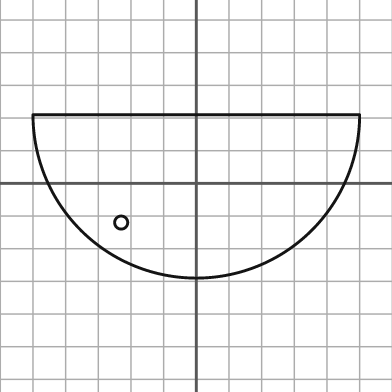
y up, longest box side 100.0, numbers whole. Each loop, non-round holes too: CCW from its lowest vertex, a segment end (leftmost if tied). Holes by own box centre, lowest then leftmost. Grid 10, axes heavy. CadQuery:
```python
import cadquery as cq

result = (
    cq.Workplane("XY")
    .moveTo(-50.0, 21.0)
    .threePointArc((0.0, -29.0), (50.0, 21.0))
    .close()
    .moveTo(-23.0, -12.0)
    .circle(2.0)
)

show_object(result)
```